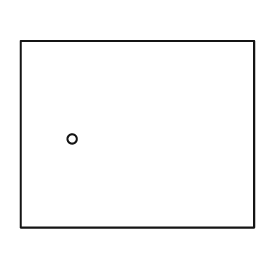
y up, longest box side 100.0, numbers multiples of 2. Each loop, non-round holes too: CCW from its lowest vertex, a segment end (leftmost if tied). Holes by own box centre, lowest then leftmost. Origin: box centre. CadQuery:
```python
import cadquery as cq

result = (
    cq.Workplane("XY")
    .moveTo(-50.0, -40.0)
    .lineTo(50.0, -40.0)
    .lineTo(50.0, 40.0)
    .lineTo(-50.0, 40.0)
    .close()
    .moveTo(-28.0, -2.0)
    .circle(2.0)
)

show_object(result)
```